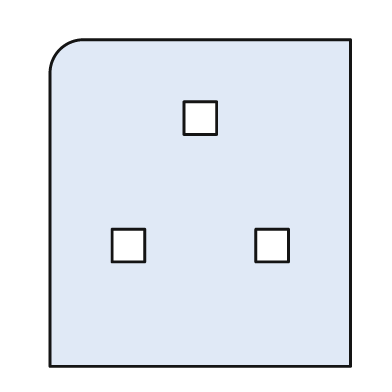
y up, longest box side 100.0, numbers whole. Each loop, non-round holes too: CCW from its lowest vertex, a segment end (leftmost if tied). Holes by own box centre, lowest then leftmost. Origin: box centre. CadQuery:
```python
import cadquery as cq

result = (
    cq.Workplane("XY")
    .moveTo(-46.0, -50.0)
    .lineTo(46.0, -50.0)
    .lineTo(46.0, 50.0)
    .lineTo(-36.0, 50.0)
    .threePointArc((-43.0, 47.0), (-46.0, 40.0))
    .close()
    .moveTo(-27.0, -18.0)
    .lineTo(-17.0, -18.0)
    .lineTo(-17.0, -8.0)
    .lineTo(-27.0, -8.0)
    .close()
    .moveTo(17.0, -18.0)
    .lineTo(27.0, -18.0)
    .lineTo(27.0, -8.0)
    .lineTo(17.0, -8.0)
    .close()
    .moveTo(-5.0, 21.0)
    .lineTo(5.0, 21.0)
    .lineTo(5.0, 31.0)
    .lineTo(-5.0, 31.0)
    .close()
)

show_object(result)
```